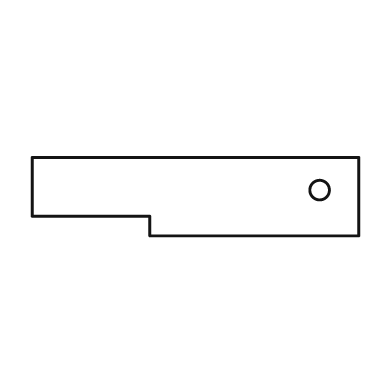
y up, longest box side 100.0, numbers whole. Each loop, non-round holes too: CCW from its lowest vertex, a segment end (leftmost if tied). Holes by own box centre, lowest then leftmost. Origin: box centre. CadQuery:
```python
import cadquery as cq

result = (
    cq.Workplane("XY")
    .moveTo(-14.0, -12.0)
    .lineTo(50.0, -12.0)
    .lineTo(50.0, 12.0)
    .lineTo(-50.0, 12.0)
    .lineTo(-50.0, -6.0)
    .lineTo(-14.0, -6.0)
    .close()
    .moveTo(38.0, 2.0)
    .circle(3.0)
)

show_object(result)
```